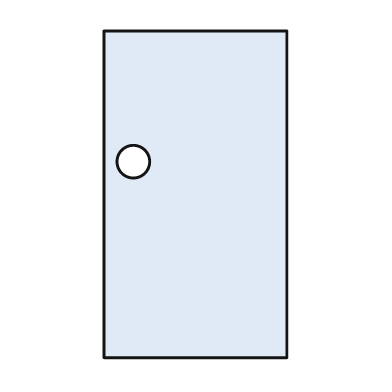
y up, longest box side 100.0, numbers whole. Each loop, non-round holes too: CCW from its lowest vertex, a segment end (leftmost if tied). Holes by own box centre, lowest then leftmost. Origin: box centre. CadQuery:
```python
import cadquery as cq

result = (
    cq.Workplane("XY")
    .moveTo(-28.0, -50.0)
    .lineTo(28.0, -50.0)
    .lineTo(28.0, 50.0)
    .lineTo(-28.0, 50.0)
    .close()
    .moveTo(-19.0, 10.0)
    .circle(5.0)
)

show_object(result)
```